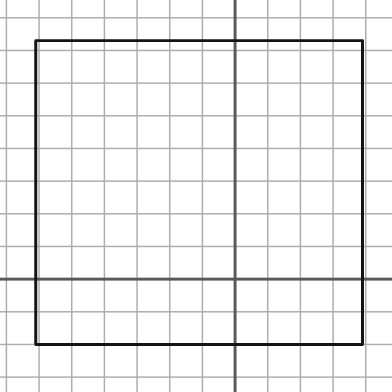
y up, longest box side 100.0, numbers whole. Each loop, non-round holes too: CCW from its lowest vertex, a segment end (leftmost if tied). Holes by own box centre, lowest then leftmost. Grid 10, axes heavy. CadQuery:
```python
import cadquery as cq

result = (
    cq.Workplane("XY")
    .moveTo(-61.0, -20.0)
    .lineTo(39.0, -20.0)
    .lineTo(39.0, 73.0)
    .lineTo(-61.0, 73.0)
    .close()
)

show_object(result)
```